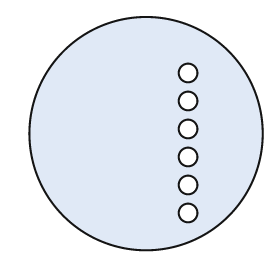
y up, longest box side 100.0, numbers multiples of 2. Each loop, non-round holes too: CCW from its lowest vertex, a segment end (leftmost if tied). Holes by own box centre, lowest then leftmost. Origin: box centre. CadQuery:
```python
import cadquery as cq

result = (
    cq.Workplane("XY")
    .moveTo(0.0, 0.0)
    .circle(50.0)
    .moveTo(18.0, -34.0)
    .circle(4.0)
    .moveTo(18.0, -22.0)
    .circle(4.0)
    .moveTo(18.0, -10.0)
    .circle(4.0)
    .moveTo(18.0, 2.0)
    .circle(4.0)
    .moveTo(18.0, 14.0)
    .circle(4.0)
    .moveTo(18.0, 26.0)
    .circle(4.0)
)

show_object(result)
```